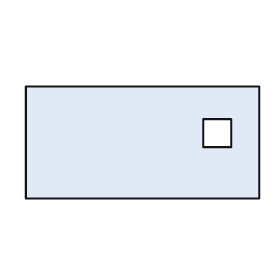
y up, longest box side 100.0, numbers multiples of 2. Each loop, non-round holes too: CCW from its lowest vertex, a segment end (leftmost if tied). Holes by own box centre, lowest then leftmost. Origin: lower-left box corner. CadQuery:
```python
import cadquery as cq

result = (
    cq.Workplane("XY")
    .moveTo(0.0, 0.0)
    .lineTo(100.0, 0.0)
    .lineTo(100.0, 48.0)
    .lineTo(0.0, 48.0)
    .close()
    .moveTo(76.0, 22.0)
    .lineTo(88.0, 22.0)
    .lineTo(88.0, 34.0)
    .lineTo(76.0, 34.0)
    .close()
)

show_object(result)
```